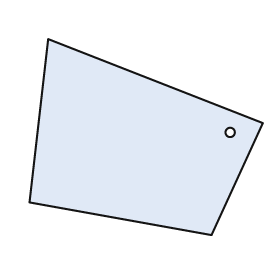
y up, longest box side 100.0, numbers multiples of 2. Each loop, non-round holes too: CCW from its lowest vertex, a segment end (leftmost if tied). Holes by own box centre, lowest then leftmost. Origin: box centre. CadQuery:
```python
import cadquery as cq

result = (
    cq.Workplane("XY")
    .moveTo(28.0, -42.0)
    .lineTo(50.0, 6.0)
    .lineTo(-42.0, 42.0)
    .lineTo(-50.0, -28.0)
    .close()
    .moveTo(36.0, 2.0)
    .circle(2.0)
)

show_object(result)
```